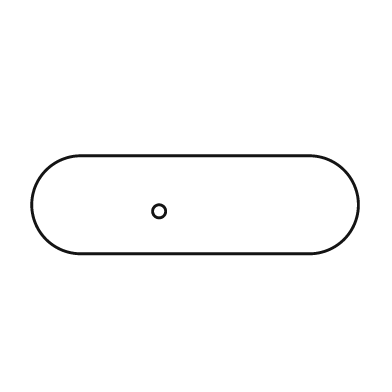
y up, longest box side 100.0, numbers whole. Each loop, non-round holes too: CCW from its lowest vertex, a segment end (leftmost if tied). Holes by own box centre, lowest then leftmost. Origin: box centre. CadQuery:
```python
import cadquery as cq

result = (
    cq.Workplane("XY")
    .moveTo(-35.0, -15.0)
    .lineTo(35.0, -15.0)
    .threePointArc((50.0, 0.0), (35.0, 15.0))
    .lineTo(-35.0, 15.0)
    .threePointArc((-50.0, 0.0), (-35.0, -15.0))
    .close()
    .moveTo(-11.0, -2.0)
    .circle(2.0)
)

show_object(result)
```